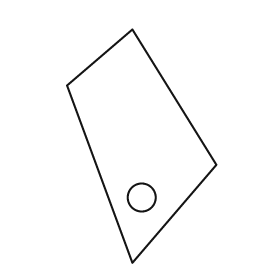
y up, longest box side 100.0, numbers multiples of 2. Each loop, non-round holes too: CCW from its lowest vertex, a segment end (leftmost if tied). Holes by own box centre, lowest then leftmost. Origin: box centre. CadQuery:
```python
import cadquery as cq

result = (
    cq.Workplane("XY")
    .moveTo(-4.0, -50.0)
    .lineTo(32.0, -8.0)
    .lineTo(-4.0, 50.0)
    .lineTo(-32.0, 26.0)
    .close()
    .moveTo(0.0, -22.0)
    .circle(6.0)
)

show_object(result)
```